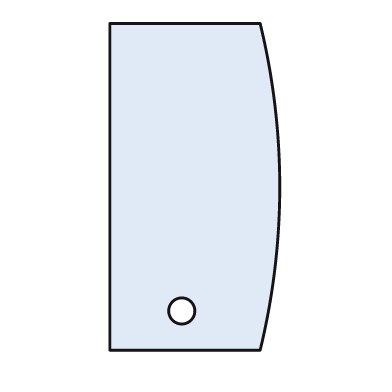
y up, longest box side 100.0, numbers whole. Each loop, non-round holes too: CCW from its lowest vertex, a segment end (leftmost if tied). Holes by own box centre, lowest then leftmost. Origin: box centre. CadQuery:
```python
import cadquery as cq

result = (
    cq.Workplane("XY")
    .moveTo(-26.0, -50.0)
    .lineTo(20.0, -50.0)
    .threePointArc((26.0, 0.0), (20.0, 50.0))
    .lineTo(-26.0, 50.0)
    .close()
    .moveTo(-4.0, -38.0)
    .circle(4.0)
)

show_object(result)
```